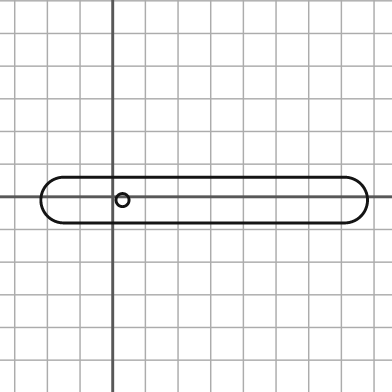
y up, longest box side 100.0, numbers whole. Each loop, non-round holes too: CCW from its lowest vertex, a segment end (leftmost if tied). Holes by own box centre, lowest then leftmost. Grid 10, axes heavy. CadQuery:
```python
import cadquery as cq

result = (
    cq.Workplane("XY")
    .moveTo(-15.0, -8.0)
    .lineTo(71.0, -8.0)
    .threePointArc((78.0, -1.0), (71.0, 6.0))
    .lineTo(-15.0, 6.0)
    .threePointArc((-22.0, -1.0), (-15.0, -8.0))
    .close()
    .moveTo(3.0, -1.0)
    .circle(2.0)
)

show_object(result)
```